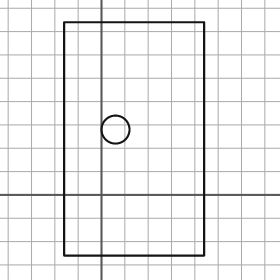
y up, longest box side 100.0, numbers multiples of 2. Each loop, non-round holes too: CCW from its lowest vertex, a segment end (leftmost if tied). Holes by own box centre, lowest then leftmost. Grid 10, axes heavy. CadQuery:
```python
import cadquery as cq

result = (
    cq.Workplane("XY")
    .moveTo(-16.0, -26.0)
    .lineTo(44.0, -26.0)
    .lineTo(44.0, 74.0)
    .lineTo(-16.0, 74.0)
    .close()
    .moveTo(6.0, 28.0)
    .circle(6.0)
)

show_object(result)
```